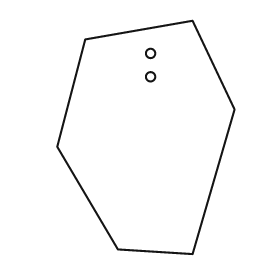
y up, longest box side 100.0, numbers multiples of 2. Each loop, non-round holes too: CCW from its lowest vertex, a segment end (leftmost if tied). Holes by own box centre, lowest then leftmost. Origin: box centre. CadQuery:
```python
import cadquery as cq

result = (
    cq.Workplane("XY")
    .moveTo(20.0, -50.0)
    .lineTo(38.0, 12.0)
    .lineTo(20.0, 50.0)
    .lineTo(-26.0, 42.0)
    .lineTo(-38.0, -4.0)
    .lineTo(-12.0, -48.0)
    .close()
    .moveTo(2.0, 26.0)
    .circle(2.0)
    .moveTo(2.0, 36.0)
    .circle(2.0)
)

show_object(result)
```